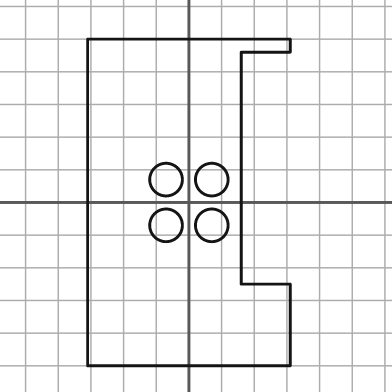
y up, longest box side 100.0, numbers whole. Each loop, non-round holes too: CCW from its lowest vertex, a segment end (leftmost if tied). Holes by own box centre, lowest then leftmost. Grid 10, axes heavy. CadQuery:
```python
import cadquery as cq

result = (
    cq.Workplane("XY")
    .moveTo(-31.0, -50.0)
    .lineTo(31.0, -50.0)
    .lineTo(31.0, -25.0)
    .lineTo(16.0, -25.0)
    .lineTo(16.0, 46.0)
    .lineTo(31.0, 46.0)
    .lineTo(31.0, 50.0)
    .lineTo(-31.0, 50.0)
    .close()
    .moveTo(-7.0, -7.0)
    .circle(5.0)
    .moveTo(7.0, -7.0)
    .circle(5.0)
    .moveTo(-7.0, 7.0)
    .circle(5.0)
    .moveTo(7.0, 7.0)
    .circle(5.0)
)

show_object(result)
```